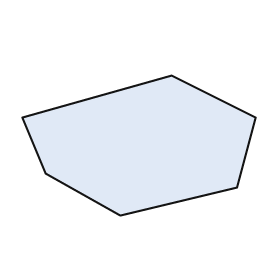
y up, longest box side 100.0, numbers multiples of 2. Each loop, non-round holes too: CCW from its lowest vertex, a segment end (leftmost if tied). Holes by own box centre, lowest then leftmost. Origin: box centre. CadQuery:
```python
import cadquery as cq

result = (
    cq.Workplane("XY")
    .moveTo(-8.0, -30.0)
    .lineTo(42.0, -18.0)
    .lineTo(50.0, 12.0)
    .lineTo(14.0, 30.0)
    .lineTo(-50.0, 12.0)
    .lineTo(-40.0, -12.0)
    .close()
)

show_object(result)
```